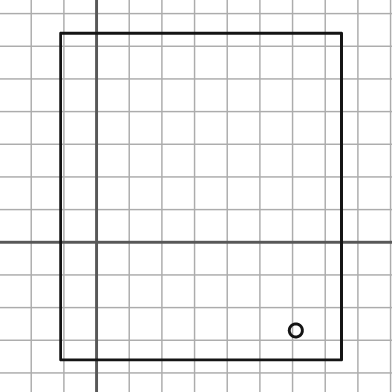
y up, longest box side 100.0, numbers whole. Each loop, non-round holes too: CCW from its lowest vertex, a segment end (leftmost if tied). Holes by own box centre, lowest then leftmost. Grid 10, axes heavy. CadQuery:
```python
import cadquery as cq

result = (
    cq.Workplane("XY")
    .moveTo(-11.0, -36.0)
    .lineTo(75.0, -36.0)
    .lineTo(75.0, 64.0)
    .lineTo(-11.0, 64.0)
    .close()
    .moveTo(61.0, -27.0)
    .circle(2.0)
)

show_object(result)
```